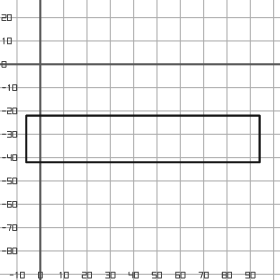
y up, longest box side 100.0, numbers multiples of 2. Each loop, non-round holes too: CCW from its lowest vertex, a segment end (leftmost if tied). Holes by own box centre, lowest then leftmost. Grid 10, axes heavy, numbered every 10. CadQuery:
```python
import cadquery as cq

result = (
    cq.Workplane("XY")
    .moveTo(-6.0, -42.0)
    .lineTo(94.0, -42.0)
    .lineTo(94.0, -22.0)
    .lineTo(-6.0, -22.0)
    .close()
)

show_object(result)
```